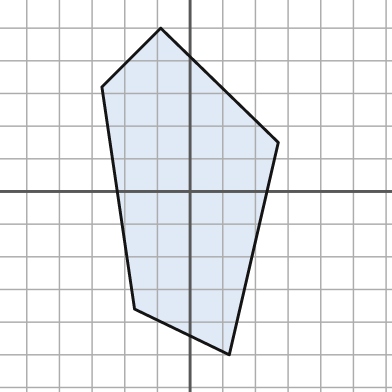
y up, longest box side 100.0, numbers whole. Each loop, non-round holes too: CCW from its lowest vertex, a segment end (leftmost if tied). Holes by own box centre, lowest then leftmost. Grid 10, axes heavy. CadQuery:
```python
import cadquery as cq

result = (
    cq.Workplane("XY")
    .moveTo(12.0, -50.0)
    .lineTo(27.0, 15.0)
    .lineTo(-9.0, 50.0)
    .lineTo(-27.0, 32.0)
    .lineTo(-17.0, -36.0)
    .close()
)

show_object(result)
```